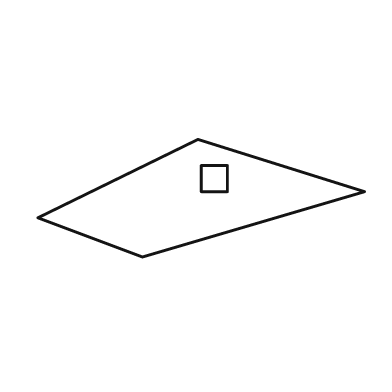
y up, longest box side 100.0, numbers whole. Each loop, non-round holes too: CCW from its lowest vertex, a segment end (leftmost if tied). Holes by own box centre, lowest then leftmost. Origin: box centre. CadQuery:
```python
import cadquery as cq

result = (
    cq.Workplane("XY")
    .moveTo(-18.0, -18.0)
    .lineTo(50.0, 2.0)
    .lineTo(-1.0, 18.0)
    .lineTo(-50.0, -6.0)
    .close()
    .moveTo(0.0, 2.0)
    .lineTo(8.0, 2.0)
    .lineTo(8.0, 10.0)
    .lineTo(0.0, 10.0)
    .close()
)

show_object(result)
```